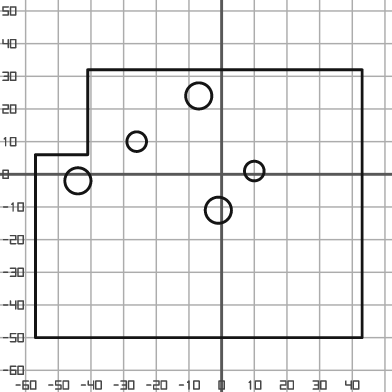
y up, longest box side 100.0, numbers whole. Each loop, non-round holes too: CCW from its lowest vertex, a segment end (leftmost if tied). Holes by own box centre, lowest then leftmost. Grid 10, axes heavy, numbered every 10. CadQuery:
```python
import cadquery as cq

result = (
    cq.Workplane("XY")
    .moveTo(-57.0, -50.0)
    .lineTo(43.0, -50.0)
    .lineTo(43.0, 32.0)
    .lineTo(-41.0, 32.0)
    .lineTo(-41.0, 6.0)
    .lineTo(-57.0, 6.0)
    .close()
    .moveTo(-1.0, -11.0)
    .circle(4.0)
    .moveTo(-44.0, -2.0)
    .circle(4.0)
    .moveTo(10.0, 1.0)
    .circle(3.0)
    .moveTo(-26.0, 10.0)
    .circle(3.0)
    .moveTo(-7.0, 24.0)
    .circle(4.0)
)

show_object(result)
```